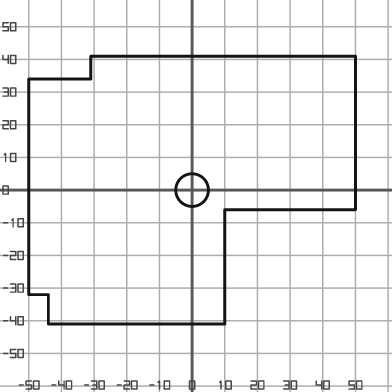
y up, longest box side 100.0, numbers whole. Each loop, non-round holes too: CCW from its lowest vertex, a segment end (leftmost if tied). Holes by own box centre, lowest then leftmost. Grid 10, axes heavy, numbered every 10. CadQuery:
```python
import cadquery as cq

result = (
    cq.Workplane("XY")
    .moveTo(-44.0, -41.0)
    .lineTo(10.0, -41.0)
    .lineTo(10.0, -6.0)
    .lineTo(50.0, -6.0)
    .lineTo(50.0, 41.0)
    .lineTo(-31.0, 41.0)
    .lineTo(-31.0, 34.0)
    .lineTo(-50.0, 34.0)
    .lineTo(-50.0, -32.0)
    .lineTo(-44.0, -32.0)
    .close()
    .moveTo(0.0, 0.0)
    .circle(5.0)
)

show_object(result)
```